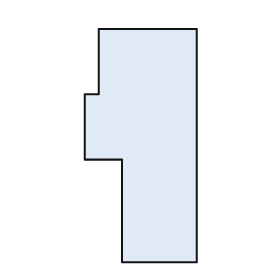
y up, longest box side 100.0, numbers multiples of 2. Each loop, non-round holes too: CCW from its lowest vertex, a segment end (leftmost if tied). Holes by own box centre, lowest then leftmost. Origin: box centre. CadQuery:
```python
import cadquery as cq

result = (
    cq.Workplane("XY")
    .moveTo(-8.0, -50.0)
    .lineTo(24.0, -50.0)
    .lineTo(24.0, 50.0)
    .lineTo(-18.0, 50.0)
    .lineTo(-18.0, 22.0)
    .lineTo(-24.0, 22.0)
    .lineTo(-24.0, -6.0)
    .lineTo(-8.0, -6.0)
    .close()
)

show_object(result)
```